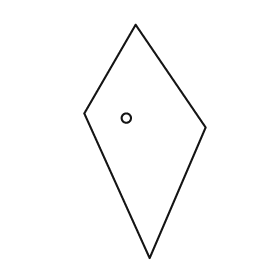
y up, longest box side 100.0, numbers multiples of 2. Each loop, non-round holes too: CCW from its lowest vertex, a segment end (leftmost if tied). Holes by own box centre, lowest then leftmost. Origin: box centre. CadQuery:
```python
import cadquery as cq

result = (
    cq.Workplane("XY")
    .moveTo(2.0, -50.0)
    .lineTo(26.0, 6.0)
    .lineTo(-4.0, 50.0)
    .lineTo(-26.0, 12.0)
    .close()
    .moveTo(-8.0, 10.0)
    .circle(2.0)
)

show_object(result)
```